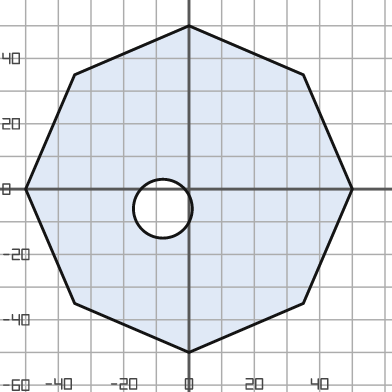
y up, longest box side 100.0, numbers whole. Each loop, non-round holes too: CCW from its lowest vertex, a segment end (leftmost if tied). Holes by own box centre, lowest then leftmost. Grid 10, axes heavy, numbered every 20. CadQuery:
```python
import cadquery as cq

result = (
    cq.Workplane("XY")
    .moveTo(0.0, -50.0)
    .lineTo(35.0, -35.0)
    .lineTo(50.0, 0.0)
    .lineTo(35.0, 35.0)
    .lineTo(0.0, 50.0)
    .lineTo(-35.0, 35.0)
    .lineTo(-50.0, 0.0)
    .lineTo(-35.0, -35.0)
    .close()
    .moveTo(-8.0, -6.0)
    .circle(9.0)
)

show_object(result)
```